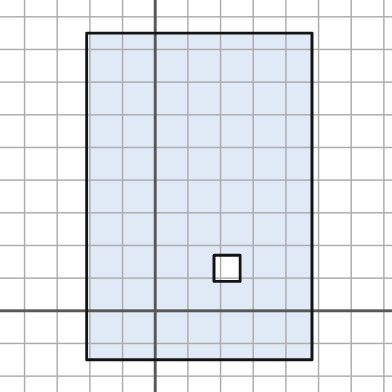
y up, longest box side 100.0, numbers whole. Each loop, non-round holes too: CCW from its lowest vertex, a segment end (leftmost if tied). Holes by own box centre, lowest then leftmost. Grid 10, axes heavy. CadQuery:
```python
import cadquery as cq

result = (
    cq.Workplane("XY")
    .moveTo(-21.0, -15.0)
    .lineTo(48.0, -15.0)
    .lineTo(48.0, 85.0)
    .lineTo(-21.0, 85.0)
    .close()
    .moveTo(18.0, 9.0)
    .lineTo(26.0, 9.0)
    .lineTo(26.0, 17.0)
    .lineTo(18.0, 17.0)
    .close()
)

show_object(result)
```